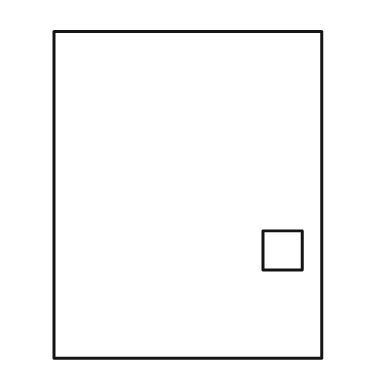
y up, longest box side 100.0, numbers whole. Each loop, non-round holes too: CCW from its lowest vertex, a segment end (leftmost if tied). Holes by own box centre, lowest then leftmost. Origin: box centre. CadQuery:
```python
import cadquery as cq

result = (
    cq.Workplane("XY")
    .moveTo(-41.0, -50.0)
    .lineTo(41.0, -50.0)
    .lineTo(41.0, 50.0)
    .lineTo(-41.0, 50.0)
    .close()
    .moveTo(23.0, -23.0)
    .lineTo(35.0, -23.0)
    .lineTo(35.0, -11.0)
    .lineTo(23.0, -11.0)
    .close()
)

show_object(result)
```